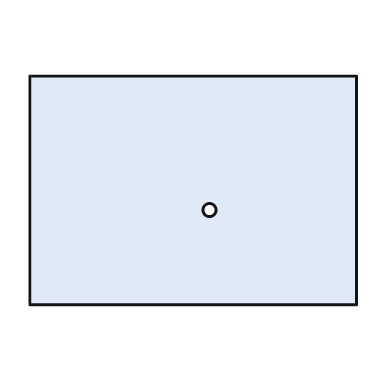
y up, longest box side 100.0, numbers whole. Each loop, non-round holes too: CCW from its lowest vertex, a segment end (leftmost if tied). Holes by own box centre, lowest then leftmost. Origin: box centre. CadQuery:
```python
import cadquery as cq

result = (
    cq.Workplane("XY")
    .moveTo(-50.0, -35.0)
    .lineTo(50.0, -35.0)
    .lineTo(50.0, 35.0)
    .lineTo(-50.0, 35.0)
    .close()
    .moveTo(5.0, -6.0)
    .circle(2.0)
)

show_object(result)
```